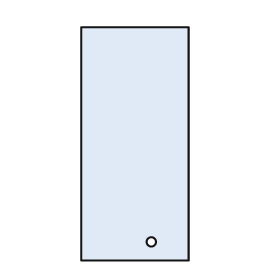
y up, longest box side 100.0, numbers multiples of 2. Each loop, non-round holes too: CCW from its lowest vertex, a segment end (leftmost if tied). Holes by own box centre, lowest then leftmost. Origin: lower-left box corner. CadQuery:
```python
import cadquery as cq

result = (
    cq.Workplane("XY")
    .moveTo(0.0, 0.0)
    .lineTo(46.0, 0.0)
    .lineTo(46.0, 100.0)
    .lineTo(0.0, 100.0)
    .close()
    .moveTo(30.0, 8.0)
    .circle(2.0)
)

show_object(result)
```